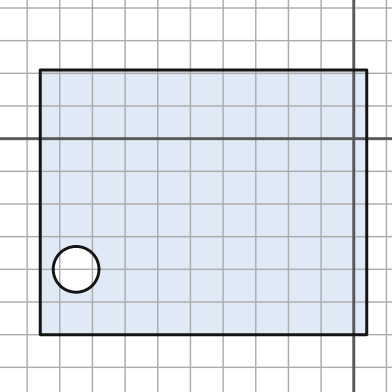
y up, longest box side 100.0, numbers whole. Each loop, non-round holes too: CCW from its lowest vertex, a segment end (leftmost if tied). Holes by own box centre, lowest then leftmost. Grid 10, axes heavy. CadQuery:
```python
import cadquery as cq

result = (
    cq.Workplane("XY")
    .moveTo(-96.0, -60.0)
    .lineTo(4.0, -60.0)
    .lineTo(4.0, 21.0)
    .lineTo(-96.0, 21.0)
    .close()
    .moveTo(-85.0, -40.0)
    .circle(7.0)
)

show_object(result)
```